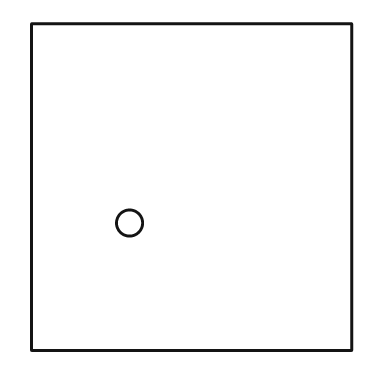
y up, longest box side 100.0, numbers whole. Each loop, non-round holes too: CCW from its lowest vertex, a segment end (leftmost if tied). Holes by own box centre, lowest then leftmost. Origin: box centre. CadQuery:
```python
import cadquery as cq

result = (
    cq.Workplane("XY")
    .moveTo(-49.0, -50.0)
    .lineTo(49.0, -50.0)
    .lineTo(49.0, 50.0)
    .lineTo(-49.0, 50.0)
    .close()
    .moveTo(-19.0, -11.0)
    .circle(4.0)
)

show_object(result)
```